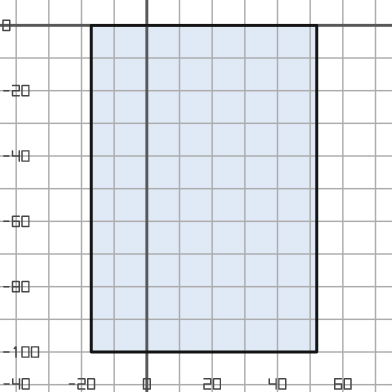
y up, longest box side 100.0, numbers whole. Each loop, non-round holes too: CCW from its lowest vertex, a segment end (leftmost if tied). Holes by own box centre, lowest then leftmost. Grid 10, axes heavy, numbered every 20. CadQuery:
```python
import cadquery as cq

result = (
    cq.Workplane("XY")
    .moveTo(-17.0, -100.0)
    .lineTo(52.0, -100.0)
    .lineTo(52.0, 0.0)
    .lineTo(-17.0, 0.0)
    .close()
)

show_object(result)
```